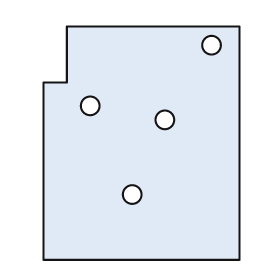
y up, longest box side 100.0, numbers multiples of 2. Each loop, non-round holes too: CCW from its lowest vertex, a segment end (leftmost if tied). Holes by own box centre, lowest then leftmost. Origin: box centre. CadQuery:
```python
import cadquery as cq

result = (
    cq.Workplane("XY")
    .moveTo(-42.0, -50.0)
    .lineTo(42.0, -50.0)
    .lineTo(42.0, 50.0)
    .lineTo(-32.0, 50.0)
    .lineTo(-32.0, 26.0)
    .lineTo(-42.0, 26.0)
    .close()
    .moveTo(-4.0, -22.0)
    .circle(4.0)
    .moveTo(10.0, 10.0)
    .circle(4.0)
    .moveTo(-22.0, 16.0)
    .circle(4.0)
    .moveTo(30.0, 42.0)
    .circle(4.0)
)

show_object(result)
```